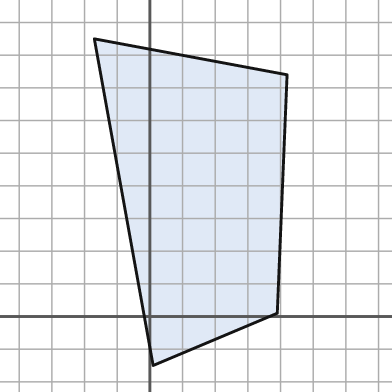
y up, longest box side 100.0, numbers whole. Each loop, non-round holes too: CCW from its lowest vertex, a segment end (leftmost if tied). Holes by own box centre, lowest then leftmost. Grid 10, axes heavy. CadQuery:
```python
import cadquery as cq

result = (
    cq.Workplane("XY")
    .moveTo(1.0, -15.0)
    .lineTo(39.0, 1.0)
    .lineTo(42.0, 74.0)
    .lineTo(-17.0, 85.0)
    .close()
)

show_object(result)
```